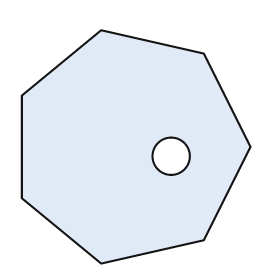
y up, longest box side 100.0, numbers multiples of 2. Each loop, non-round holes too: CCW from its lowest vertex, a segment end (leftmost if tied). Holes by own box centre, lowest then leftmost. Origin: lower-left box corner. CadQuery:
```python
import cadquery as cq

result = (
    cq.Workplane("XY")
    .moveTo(34.0, 0.0)
    .lineTo(78.0, 10.0)
    .lineTo(98.0, 50.0)
    .lineTo(78.0, 90.0)
    .lineTo(34.0, 100.0)
    .lineTo(0.0, 72.0)
    .lineTo(0.0, 28.0)
    .close()
    .moveTo(64.0, 46.0)
    .circle(8.0)
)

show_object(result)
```